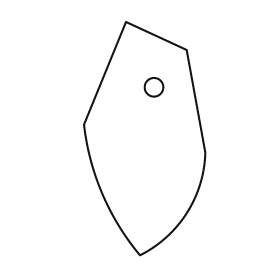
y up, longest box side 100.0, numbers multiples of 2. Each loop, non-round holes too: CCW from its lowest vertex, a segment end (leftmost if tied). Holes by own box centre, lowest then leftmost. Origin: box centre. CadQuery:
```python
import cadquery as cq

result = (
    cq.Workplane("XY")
    .moveTo(-2.0, -50.0)
    .threePointArc((18.0, -32.0), (26.0, -6.0))
    .lineTo(18.0, 38.0)
    .lineTo(-8.0, 50.0)
    .lineTo(-26.0, 6.0)
    .threePointArc((-18.0, -24.0), (-2.0, -50.0))
    .close()
    .moveTo(4.0, 22.0)
    .circle(4.0)
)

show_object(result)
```